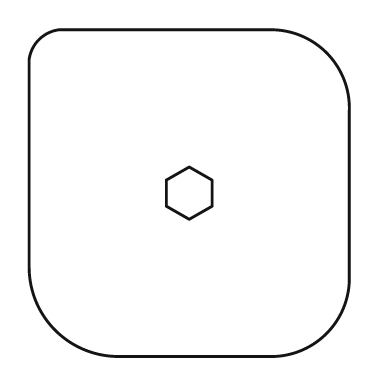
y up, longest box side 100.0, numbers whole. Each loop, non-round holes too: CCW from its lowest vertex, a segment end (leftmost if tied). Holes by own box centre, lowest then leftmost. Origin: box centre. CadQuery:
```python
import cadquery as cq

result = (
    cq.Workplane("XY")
    .moveTo(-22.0, -50.0)
    .lineTo(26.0, -50.0)
    .threePointArc((42.0, -43.0), (49.0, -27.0))
    .lineTo(49.0, 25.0)
    .threePointArc((42.0, 43.0), (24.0, 50.0))
    .lineTo(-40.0, 50.0)
    .threePointArc((-46.0, 47.0), (-49.0, 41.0))
    .lineTo(-49.0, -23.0)
    .threePointArc((-41.0, -42.0), (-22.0, -50.0))
    .close()
    .moveTo(0.0, -8.0)
    .lineTo(7.0, -4.0)
    .lineTo(7.0, 4.0)
    .lineTo(0.0, 8.0)
    .lineTo(-7.0, 4.0)
    .lineTo(-7.0, -4.0)
    .close()
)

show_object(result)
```